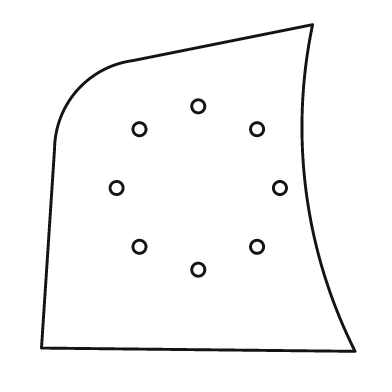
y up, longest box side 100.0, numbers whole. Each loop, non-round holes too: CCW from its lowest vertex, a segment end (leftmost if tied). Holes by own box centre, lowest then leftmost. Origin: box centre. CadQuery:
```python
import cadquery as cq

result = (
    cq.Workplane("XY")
    .moveTo(48.0, -50.0)
    .threePointArc((33.0, -1.0), (35.0, 50.0))
    .lineTo(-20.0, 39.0)
    .threePointArc((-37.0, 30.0), (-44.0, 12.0))
    .lineTo(-48.0, -49.0)
    .close()
    .moveTo(0.0, -25.0)
    .circle(2.0)
    .moveTo(-18.0, -18.0)
    .circle(2.0)
    .moveTo(18.0, -18.0)
    .circle(2.0)
    .moveTo(-25.0, 0.0)
    .circle(2.0)
    .moveTo(25.0, 0.0)
    .circle(2.0)
    .moveTo(-18.0, 18.0)
    .circle(2.0)
    .moveTo(18.0, 18.0)
    .circle(2.0)
    .moveTo(0.0, 25.0)
    .circle(2.0)
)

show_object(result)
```